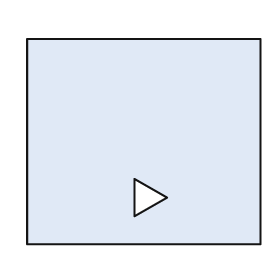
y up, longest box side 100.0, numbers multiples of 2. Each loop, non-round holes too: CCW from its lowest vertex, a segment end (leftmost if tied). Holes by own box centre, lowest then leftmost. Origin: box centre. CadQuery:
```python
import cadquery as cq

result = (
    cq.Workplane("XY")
    .moveTo(-50.0, -44.0)
    .lineTo(50.0, -44.0)
    .lineTo(50.0, 44.0)
    .lineTo(-50.0, 44.0)
    .close()
    .moveTo(-4.0, -32.0)
    .lineTo(10.0, -24.0)
    .lineTo(-4.0, -16.0)
    .close()
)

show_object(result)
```